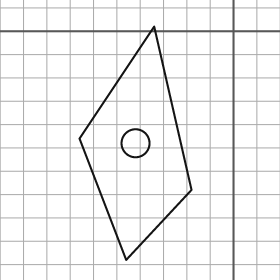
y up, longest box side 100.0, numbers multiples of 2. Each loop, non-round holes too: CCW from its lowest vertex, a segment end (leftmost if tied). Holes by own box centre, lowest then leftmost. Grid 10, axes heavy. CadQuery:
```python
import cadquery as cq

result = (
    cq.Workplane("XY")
    .moveTo(-46.0, -98.0)
    .lineTo(-18.0, -68.0)
    .lineTo(-34.0, 2.0)
    .lineTo(-66.0, -46.0)
    .close()
    .moveTo(-42.0, -48.0)
    .circle(6.0)
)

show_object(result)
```